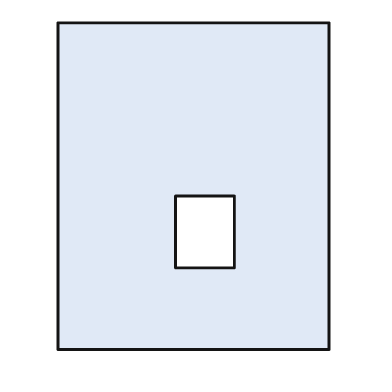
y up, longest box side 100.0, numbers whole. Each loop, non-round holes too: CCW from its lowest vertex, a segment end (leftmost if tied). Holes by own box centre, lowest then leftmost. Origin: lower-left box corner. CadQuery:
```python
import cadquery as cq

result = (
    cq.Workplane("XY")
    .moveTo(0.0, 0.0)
    .lineTo(83.0, 0.0)
    .lineTo(83.0, 100.0)
    .lineTo(0.0, 100.0)
    .close()
    .moveTo(36.0, 25.0)
    .lineTo(54.0, 25.0)
    .lineTo(54.0, 47.0)
    .lineTo(36.0, 47.0)
    .close()
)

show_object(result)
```